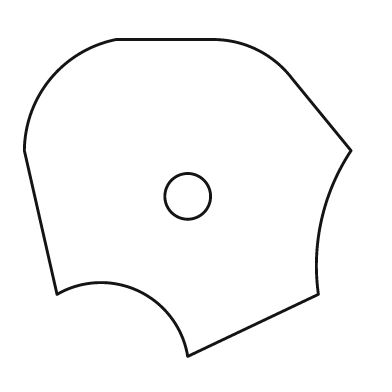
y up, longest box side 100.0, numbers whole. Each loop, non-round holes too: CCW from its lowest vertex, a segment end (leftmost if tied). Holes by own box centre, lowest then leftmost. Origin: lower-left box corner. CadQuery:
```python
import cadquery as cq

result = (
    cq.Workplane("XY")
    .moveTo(50.0, 0.0)
    .lineTo(90.0, 19.0)
    .threePointArc((91.0, 42.0), (100.0, 63.0))
    .lineTo(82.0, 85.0)
    .threePointArc((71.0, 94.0), (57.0, 97.0))
    .lineTo(28.0, 97.0)
    .threePointArc((8.0, 85.0), (0.0, 63.0))
    .lineTo(10.0, 19.0)
    .threePointArc((35.0, 20.0), (50.0, 0.0))
    .close()
    .moveTo(50.0, 49.0)
    .circle(7.0)
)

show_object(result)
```